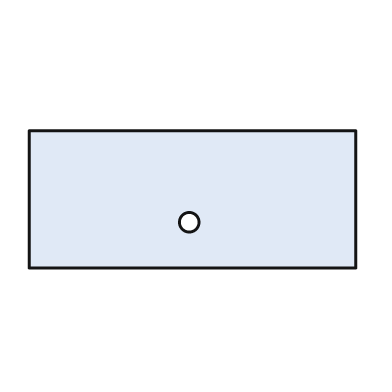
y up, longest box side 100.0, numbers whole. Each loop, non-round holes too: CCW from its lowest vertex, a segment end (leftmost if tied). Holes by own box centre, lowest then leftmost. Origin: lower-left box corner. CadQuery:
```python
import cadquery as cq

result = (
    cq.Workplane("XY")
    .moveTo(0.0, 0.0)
    .lineTo(100.0, 0.0)
    .lineTo(100.0, 42.0)
    .lineTo(0.0, 42.0)
    .close()
    .moveTo(49.0, 14.0)
    .circle(3.0)
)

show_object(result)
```